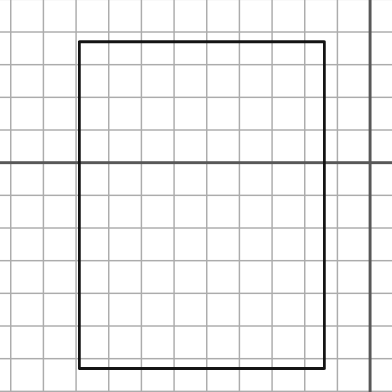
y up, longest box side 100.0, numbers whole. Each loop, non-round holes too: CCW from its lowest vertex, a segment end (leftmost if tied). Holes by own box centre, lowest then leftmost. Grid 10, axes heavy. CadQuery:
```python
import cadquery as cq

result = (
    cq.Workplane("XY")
    .moveTo(-89.0, -63.0)
    .lineTo(-14.0, -63.0)
    .lineTo(-14.0, 37.0)
    .lineTo(-89.0, 37.0)
    .close()
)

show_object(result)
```